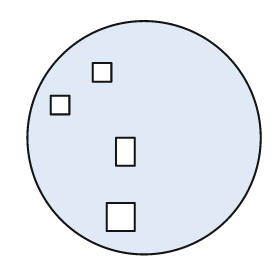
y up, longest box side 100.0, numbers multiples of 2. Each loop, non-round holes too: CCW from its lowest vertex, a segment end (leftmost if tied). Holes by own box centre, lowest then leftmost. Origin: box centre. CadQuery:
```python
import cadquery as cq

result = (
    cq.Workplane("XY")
    .moveTo(0.0, 0.0)
    .circle(50.0)
    .moveTo(-16.0, -40.0)
    .lineTo(-4.0, -40.0)
    .lineTo(-4.0, -28.0)
    .lineTo(-16.0, -28.0)
    .close()
    .moveTo(-12.0, -12.0)
    .lineTo(-4.0, -12.0)
    .lineTo(-4.0, 0.0)
    .lineTo(-12.0, 0.0)
    .close()
    .moveTo(-40.0, 10.0)
    .lineTo(-32.0, 10.0)
    .lineTo(-32.0, 18.0)
    .lineTo(-40.0, 18.0)
    .close()
    .moveTo(-22.0, 24.0)
    .lineTo(-14.0, 24.0)
    .lineTo(-14.0, 32.0)
    .lineTo(-22.0, 32.0)
    .close()
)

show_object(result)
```